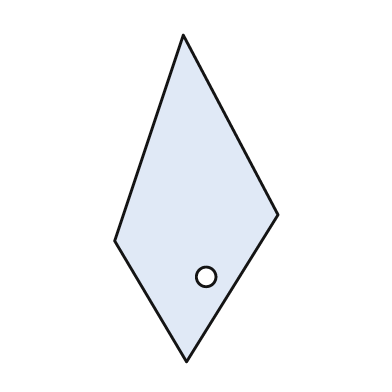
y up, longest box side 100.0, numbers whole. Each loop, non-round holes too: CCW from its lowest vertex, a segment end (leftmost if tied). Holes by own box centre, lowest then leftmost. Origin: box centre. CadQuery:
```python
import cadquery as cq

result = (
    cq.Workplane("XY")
    .moveTo(-3.0, -50.0)
    .lineTo(25.0, -5.0)
    .lineTo(-4.0, 50.0)
    .lineTo(-25.0, -13.0)
    .close()
    .moveTo(3.0, -24.0)
    .circle(3.0)
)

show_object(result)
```